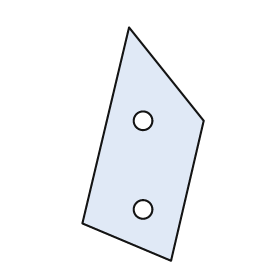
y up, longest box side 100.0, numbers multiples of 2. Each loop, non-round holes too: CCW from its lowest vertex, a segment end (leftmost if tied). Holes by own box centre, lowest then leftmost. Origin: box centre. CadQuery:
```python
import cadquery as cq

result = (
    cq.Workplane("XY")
    .moveTo(12.0, -50.0)
    .lineTo(26.0, 10.0)
    .lineTo(-6.0, 50.0)
    .lineTo(-26.0, -34.0)
    .close()
    .moveTo(0.0, -28.0)
    .circle(4.0)
    .moveTo(0.0, 10.0)
    .circle(4.0)
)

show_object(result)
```